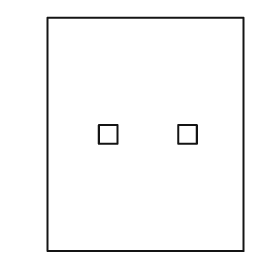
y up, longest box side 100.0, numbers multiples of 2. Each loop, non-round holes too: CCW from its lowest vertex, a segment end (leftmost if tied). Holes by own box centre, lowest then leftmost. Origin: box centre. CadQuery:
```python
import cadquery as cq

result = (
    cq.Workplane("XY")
    .moveTo(-42.0, -50.0)
    .lineTo(42.0, -50.0)
    .lineTo(42.0, 50.0)
    .lineTo(-42.0, 50.0)
    .close()
    .moveTo(-20.0, -4.0)
    .lineTo(-12.0, -4.0)
    .lineTo(-12.0, 4.0)
    .lineTo(-20.0, 4.0)
    .close()
    .moveTo(14.0, -4.0)
    .lineTo(22.0, -4.0)
    .lineTo(22.0, 4.0)
    .lineTo(14.0, 4.0)
    .close()
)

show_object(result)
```